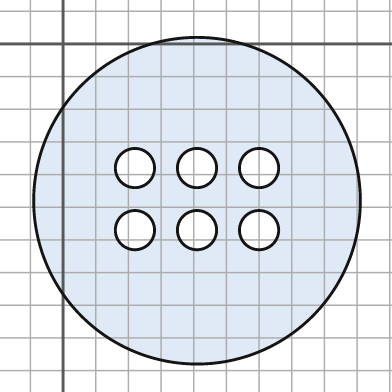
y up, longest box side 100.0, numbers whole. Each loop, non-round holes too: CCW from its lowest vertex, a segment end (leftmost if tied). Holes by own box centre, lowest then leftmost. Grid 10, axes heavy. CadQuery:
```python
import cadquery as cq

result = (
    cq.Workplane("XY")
    .moveTo(41.0, -48.0)
    .circle(50.0)
    .moveTo(22.0, -57.0)
    .circle(6.0)
    .moveTo(41.0, -57.0)
    .circle(6.0)
    .moveTo(60.0, -57.0)
    .circle(6.0)
    .moveTo(22.0, -38.0)
    .circle(6.0)
    .moveTo(41.0, -38.0)
    .circle(6.0)
    .moveTo(60.0, -38.0)
    .circle(6.0)
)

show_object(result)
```